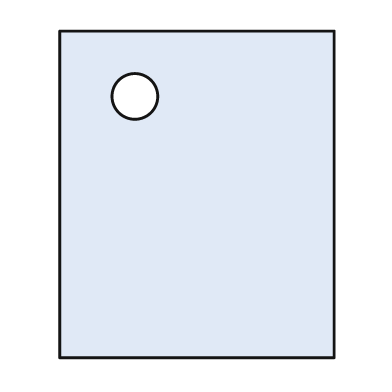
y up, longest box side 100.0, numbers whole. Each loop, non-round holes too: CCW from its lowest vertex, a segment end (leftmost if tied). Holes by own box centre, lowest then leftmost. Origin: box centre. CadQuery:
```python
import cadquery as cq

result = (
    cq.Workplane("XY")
    .moveTo(-42.0, -50.0)
    .lineTo(42.0, -50.0)
    .lineTo(42.0, 50.0)
    .lineTo(-42.0, 50.0)
    .close()
    .moveTo(-19.0, 30.0)
    .circle(7.0)
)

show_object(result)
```